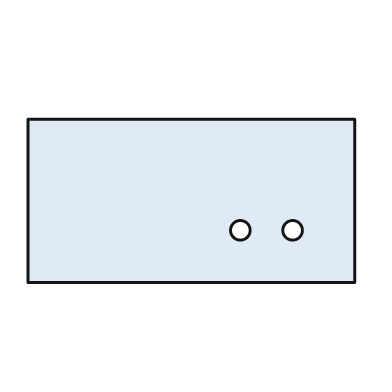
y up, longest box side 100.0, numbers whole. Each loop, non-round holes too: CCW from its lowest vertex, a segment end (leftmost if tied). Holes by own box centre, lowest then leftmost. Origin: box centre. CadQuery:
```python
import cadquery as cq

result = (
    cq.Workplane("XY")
    .moveTo(-50.0, -25.0)
    .lineTo(50.0, -25.0)
    .lineTo(50.0, 25.0)
    .lineTo(-50.0, 25.0)
    .close()
    .moveTo(15.0, -9.0)
    .circle(3.0)
    .moveTo(31.0, -9.0)
    .circle(3.0)
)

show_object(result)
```